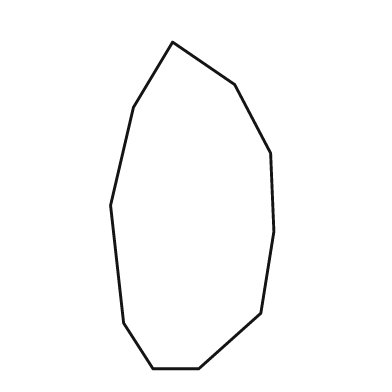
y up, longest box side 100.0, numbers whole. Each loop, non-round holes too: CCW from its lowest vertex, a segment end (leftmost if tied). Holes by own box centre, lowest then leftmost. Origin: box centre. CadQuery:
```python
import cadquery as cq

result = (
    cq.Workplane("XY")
    .moveTo(-12.0, -50.0)
    .lineTo(2.0, -50.0)
    .lineTo(21.0, -33.0)
    .lineTo(25.0, -8.0)
    .lineTo(24.0, 16.0)
    .lineTo(13.0, 37.0)
    .lineTo(-6.0, 50.0)
    .lineTo(-18.0, 30.0)
    .lineTo(-25.0, 0.0)
    .lineTo(-21.0, -36.0)
    .close()
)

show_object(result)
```